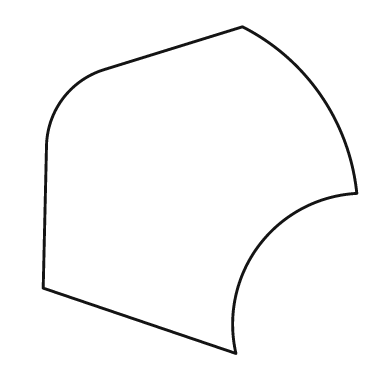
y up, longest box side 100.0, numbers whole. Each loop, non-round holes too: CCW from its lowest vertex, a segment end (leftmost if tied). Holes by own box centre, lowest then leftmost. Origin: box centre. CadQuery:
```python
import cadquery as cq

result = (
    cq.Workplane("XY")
    .moveTo(11.0, -50.0)
    .threePointArc((18.0, -17.0), (48.0, -1.0))
    .threePointArc((37.0, 29.0), (13.0, 50.0))
    .lineTo(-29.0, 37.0)
    .threePointArc((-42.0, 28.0), (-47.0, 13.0))
    .lineTo(-48.0, -30.0)
    .close()
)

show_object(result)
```